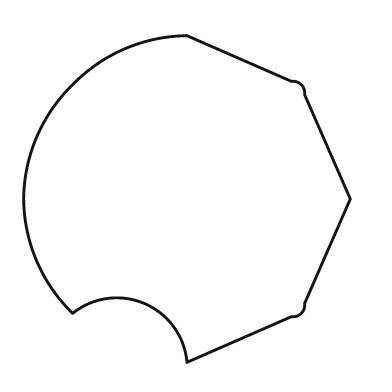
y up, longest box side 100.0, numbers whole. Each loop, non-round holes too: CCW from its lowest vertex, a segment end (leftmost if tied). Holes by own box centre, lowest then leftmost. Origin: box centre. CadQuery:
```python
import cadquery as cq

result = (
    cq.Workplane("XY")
    .moveTo(0.0, -50.0)
    .lineTo(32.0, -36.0)
    .threePointArc((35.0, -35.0), (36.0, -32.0))
    .lineTo(50.0, 0.0)
    .lineTo(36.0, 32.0)
    .threePointArc((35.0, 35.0), (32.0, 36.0))
    .lineTo(0.0, 50.0)
    .threePointArc((-19.0, 46.0), (-35.0, 35.0))
    .threePointArc((-46.0, 19.0), (-50.0, 0.0))
    .threePointArc((-46.0, -19.0), (-35.0, -35.0))
    .threePointArc((-13.0, -32.0), (0.0, -50.0))
    .close()
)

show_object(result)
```